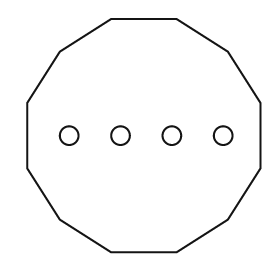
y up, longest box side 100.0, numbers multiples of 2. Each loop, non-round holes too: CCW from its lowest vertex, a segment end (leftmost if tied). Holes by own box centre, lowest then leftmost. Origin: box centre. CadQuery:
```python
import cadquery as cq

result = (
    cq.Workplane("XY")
    .moveTo(-14.0, -50.0)
    .lineTo(14.0, -50.0)
    .lineTo(36.0, -36.0)
    .lineTo(50.0, -14.0)
    .lineTo(50.0, 14.0)
    .lineTo(36.0, 36.0)
    .lineTo(14.0, 50.0)
    .lineTo(-14.0, 50.0)
    .lineTo(-36.0, 36.0)
    .lineTo(-50.0, 14.0)
    .lineTo(-50.0, -14.0)
    .lineTo(-36.0, -36.0)
    .close()
    .moveTo(-32.0, 0.0)
    .circle(4.0)
    .moveTo(-10.0, 0.0)
    .circle(4.0)
    .moveTo(12.0, 0.0)
    .circle(4.0)
    .moveTo(34.0, 0.0)
    .circle(4.0)
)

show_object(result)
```